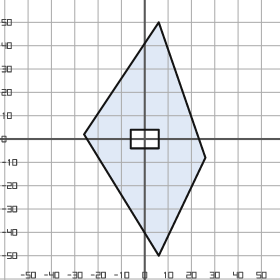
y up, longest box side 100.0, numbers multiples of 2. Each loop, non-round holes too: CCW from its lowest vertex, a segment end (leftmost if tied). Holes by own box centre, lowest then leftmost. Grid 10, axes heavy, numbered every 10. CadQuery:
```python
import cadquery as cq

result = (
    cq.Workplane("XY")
    .moveTo(6.0, -50.0)
    .lineTo(26.0, -8.0)
    .lineTo(6.0, 50.0)
    .lineTo(-26.0, 2.0)
    .close()
    .moveTo(-6.0, -4.0)
    .lineTo(6.0, -4.0)
    .lineTo(6.0, 4.0)
    .lineTo(-6.0, 4.0)
    .close()
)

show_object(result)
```